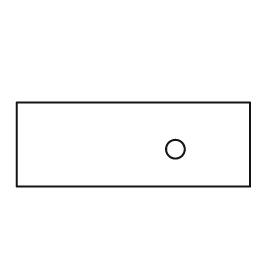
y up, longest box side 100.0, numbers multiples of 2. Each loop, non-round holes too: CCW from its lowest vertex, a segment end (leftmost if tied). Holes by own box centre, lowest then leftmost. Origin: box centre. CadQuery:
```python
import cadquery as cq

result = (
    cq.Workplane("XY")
    .moveTo(-50.0, -18.0)
    .lineTo(50.0, -18.0)
    .lineTo(50.0, 18.0)
    .lineTo(-50.0, 18.0)
    .close()
    .moveTo(18.0, -2.0)
    .circle(4.0)
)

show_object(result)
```